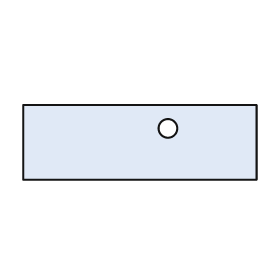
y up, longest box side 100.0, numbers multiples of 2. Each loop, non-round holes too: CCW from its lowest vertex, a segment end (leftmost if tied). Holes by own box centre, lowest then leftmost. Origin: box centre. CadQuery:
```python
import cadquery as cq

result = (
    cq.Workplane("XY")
    .moveTo(-50.0, -16.0)
    .lineTo(50.0, -16.0)
    .lineTo(50.0, 16.0)
    .lineTo(-50.0, 16.0)
    .close()
    .moveTo(12.0, 6.0)
    .circle(4.0)
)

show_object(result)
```